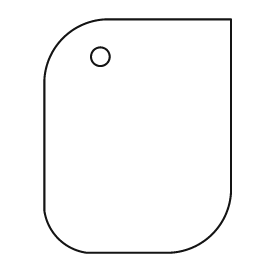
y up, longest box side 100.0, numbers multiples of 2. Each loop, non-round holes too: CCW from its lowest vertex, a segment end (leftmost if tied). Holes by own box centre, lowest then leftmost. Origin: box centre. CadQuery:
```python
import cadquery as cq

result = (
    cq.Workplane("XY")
    .moveTo(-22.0, -50.0)
    .lineTo(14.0, -50.0)
    .threePointArc((32.0, -42.0), (40.0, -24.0))
    .lineTo(40.0, 50.0)
    .lineTo(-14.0, 50.0)
    .threePointArc((-32.0, 42.0), (-40.0, 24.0))
    .lineTo(-40.0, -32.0)
    .threePointArc((-34.0, -44.0), (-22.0, -50.0))
    .close()
    .moveTo(-16.0, 34.0)
    .circle(4.0)
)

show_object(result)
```